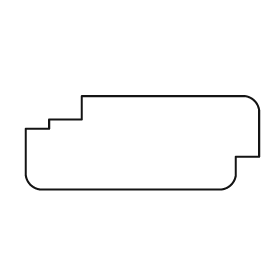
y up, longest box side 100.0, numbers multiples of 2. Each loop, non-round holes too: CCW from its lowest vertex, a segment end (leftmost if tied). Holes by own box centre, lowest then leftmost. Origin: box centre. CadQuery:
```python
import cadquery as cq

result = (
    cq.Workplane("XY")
    .moveTo(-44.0, -20.0)
    .lineTo(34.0, -20.0)
    .threePointArc((38.0, -18.0), (40.0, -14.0))
    .lineTo(40.0, -6.0)
    .lineTo(50.0, -6.0)
    .lineTo(50.0, 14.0)
    .threePointArc((48.0, 18.0), (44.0, 20.0))
    .lineTo(-26.0, 20.0)
    .lineTo(-26.0, 10.0)
    .lineTo(-40.0, 10.0)
    .lineTo(-40.0, 6.0)
    .lineTo(-50.0, 6.0)
    .lineTo(-50.0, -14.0)
    .threePointArc((-48.0, -18.0), (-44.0, -20.0))
    .close()
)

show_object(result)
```